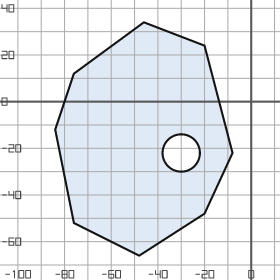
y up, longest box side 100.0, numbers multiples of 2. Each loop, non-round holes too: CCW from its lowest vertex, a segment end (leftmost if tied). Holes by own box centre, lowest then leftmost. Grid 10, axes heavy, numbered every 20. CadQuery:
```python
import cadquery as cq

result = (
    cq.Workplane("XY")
    .moveTo(-48.0, -66.0)
    .lineTo(-20.0, -48.0)
    .lineTo(-8.0, -22.0)
    .lineTo(-20.0, 24.0)
    .lineTo(-46.0, 34.0)
    .lineTo(-76.0, 12.0)
    .lineTo(-84.0, -12.0)
    .lineTo(-76.0, -52.0)
    .close()
    .moveTo(-30.0, -22.0)
    .circle(8.0)
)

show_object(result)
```